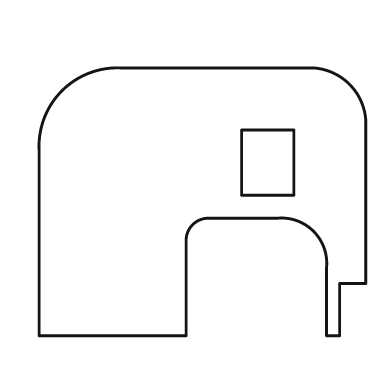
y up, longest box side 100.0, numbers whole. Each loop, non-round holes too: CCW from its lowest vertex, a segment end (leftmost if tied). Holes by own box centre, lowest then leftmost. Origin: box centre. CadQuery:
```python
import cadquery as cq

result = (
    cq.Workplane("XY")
    .moveTo(-50.0, -41.0)
    .lineTo(-5.0, -41.0)
    .lineTo(-5.0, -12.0)
    .threePointArc((-3.0, -7.0), (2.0, -5.0))
    .lineTo(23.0, -5.0)
    .threePointArc((34.0, -9.0), (38.0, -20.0))
    .lineTo(38.0, -41.0)
    .lineTo(42.0, -41.0)
    .lineTo(42.0, -25.0)
    .lineTo(50.0, -25.0)
    .lineTo(50.0, 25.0)
    .threePointArc((45.0, 36.0), (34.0, 41.0))
    .lineTo(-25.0, 41.0)
    .threePointArc((-43.0, 34.0), (-50.0, 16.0))
    .close()
    .moveTo(12.0, 2.0)
    .lineTo(28.0, 2.0)
    .lineTo(28.0, 22.0)
    .lineTo(12.0, 22.0)
    .close()
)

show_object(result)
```